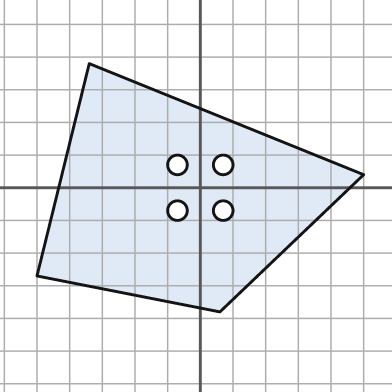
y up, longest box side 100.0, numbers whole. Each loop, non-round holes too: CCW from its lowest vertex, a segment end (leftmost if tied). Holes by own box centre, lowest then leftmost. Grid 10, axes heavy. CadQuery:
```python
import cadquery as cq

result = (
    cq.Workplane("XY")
    .moveTo(6.0, -38.0)
    .lineTo(50.0, 4.0)
    .lineTo(-34.0, 38.0)
    .lineTo(-50.0, -27.0)
    .close()
    .moveTo(-7.0, -7.0)
    .circle(3.0)
    .moveTo(7.0, -7.0)
    .circle(3.0)
    .moveTo(-7.0, 7.0)
    .circle(3.0)
    .moveTo(7.0, 7.0)
    .circle(3.0)
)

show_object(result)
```